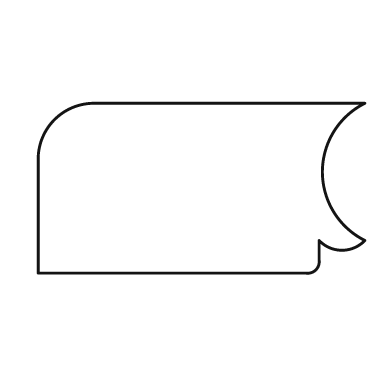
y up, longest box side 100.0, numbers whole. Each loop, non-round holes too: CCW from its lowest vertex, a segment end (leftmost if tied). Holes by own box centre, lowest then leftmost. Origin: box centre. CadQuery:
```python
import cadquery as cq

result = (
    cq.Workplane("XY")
    .moveTo(-50.0, -26.0)
    .lineTo(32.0, -26.0)
    .threePointArc((35.0, -25.0), (36.0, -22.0))
    .lineTo(36.0, -16.0)
    .threePointArc((43.0, -19.0), (50.0, -16.0))
    .threePointArc((37.0, 5.0), (50.0, 26.0))
    .lineTo(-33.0, 26.0)
    .threePointArc((-45.0, 21.0), (-50.0, 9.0))
    .close()
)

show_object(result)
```